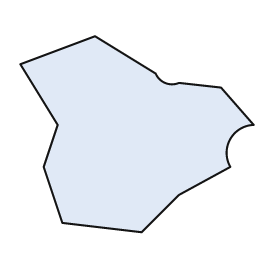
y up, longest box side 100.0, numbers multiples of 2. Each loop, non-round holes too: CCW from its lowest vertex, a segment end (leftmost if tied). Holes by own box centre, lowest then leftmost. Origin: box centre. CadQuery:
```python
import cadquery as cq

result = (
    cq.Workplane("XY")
    .moveTo(2.0, -42.0)
    .lineTo(18.0, -26.0)
    .lineTo(40.0, -14.0)
    .threePointArc((40.0, -2.0), (50.0, 4.0))
    .lineTo(36.0, 20.0)
    .lineTo(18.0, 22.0)
    .threePointArc((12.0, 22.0), (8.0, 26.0))
    .lineTo(-18.0, 42.0)
    .lineTo(-50.0, 30.0)
    .lineTo(-34.0, 4.0)
    .lineTo(-40.0, -14.0)
    .lineTo(-32.0, -38.0)
    .close()
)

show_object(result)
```